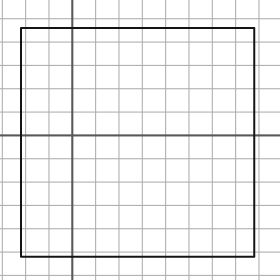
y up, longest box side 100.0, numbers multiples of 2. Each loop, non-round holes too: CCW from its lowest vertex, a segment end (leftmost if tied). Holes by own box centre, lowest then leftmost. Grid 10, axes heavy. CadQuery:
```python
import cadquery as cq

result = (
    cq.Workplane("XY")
    .moveTo(-22.0, -52.0)
    .lineTo(78.0, -52.0)
    .lineTo(78.0, 46.0)
    .lineTo(-22.0, 46.0)
    .close()
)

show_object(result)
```